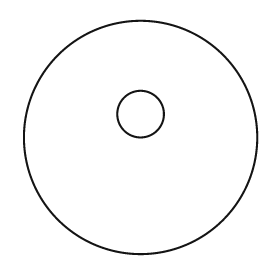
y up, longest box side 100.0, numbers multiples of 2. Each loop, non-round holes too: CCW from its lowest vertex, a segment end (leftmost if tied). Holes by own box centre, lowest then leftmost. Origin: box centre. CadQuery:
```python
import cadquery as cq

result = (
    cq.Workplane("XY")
    .moveTo(0.0, 0.0)
    .circle(50.0)
    .moveTo(0.0, 10.0)
    .circle(10.0)
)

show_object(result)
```